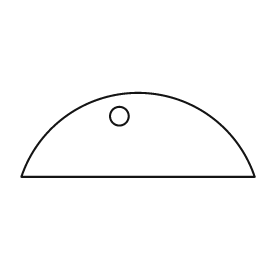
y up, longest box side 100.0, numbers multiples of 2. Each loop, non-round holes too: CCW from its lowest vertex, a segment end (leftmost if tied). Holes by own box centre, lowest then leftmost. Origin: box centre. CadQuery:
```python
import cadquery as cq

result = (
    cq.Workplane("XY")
    .moveTo(-50.0, -18.0)
    .lineTo(50.0, -18.0)
    .threePointArc((0.0, 18.0), (-50.0, -18.0))
    .close()
    .moveTo(-8.0, 8.0)
    .circle(4.0)
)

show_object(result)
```